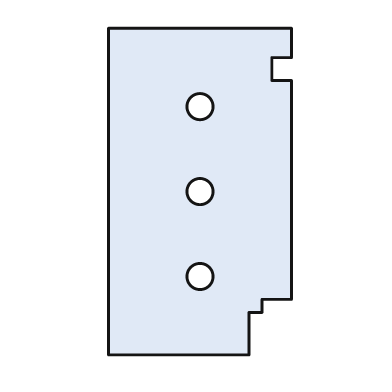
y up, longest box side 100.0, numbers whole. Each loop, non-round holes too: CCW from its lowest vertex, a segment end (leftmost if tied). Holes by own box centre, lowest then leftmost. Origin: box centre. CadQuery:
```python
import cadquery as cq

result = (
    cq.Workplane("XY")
    .moveTo(-28.0, -50.0)
    .lineTo(15.0, -50.0)
    .lineTo(15.0, -37.0)
    .lineTo(19.0, -37.0)
    .lineTo(19.0, -33.0)
    .lineTo(28.0, -33.0)
    .lineTo(28.0, 34.0)
    .lineTo(22.0, 34.0)
    .lineTo(22.0, 41.0)
    .lineTo(28.0, 41.0)
    .lineTo(28.0, 50.0)
    .lineTo(-28.0, 50.0)
    .close()
    .moveTo(0.0, -26.0)
    .circle(4.0)
    .moveTo(0.0, 0.0)
    .circle(4.0)
    .moveTo(0.0, 26.0)
    .circle(4.0)
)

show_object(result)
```